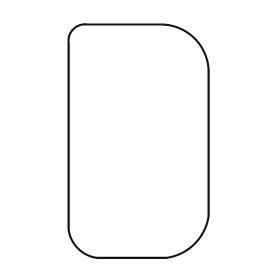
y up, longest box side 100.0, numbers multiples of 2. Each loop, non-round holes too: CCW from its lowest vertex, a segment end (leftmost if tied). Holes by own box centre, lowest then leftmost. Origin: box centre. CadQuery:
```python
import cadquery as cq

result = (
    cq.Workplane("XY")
    .moveTo(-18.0, -50.0)
    .lineTo(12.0, -50.0)
    .threePointArc((24.0, -44.0), (30.0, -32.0))
    .lineTo(30.0, 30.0)
    .threePointArc((24.0, 44.0), (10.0, 50.0))
    .lineTo(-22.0, 50.0)
    .threePointArc((-28.0, 48.0), (-30.0, 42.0))
    .lineTo(-30.0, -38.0)
    .threePointArc((-26.0, -46.0), (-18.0, -50.0))
    .close()
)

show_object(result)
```